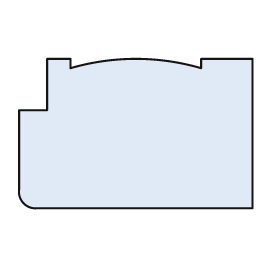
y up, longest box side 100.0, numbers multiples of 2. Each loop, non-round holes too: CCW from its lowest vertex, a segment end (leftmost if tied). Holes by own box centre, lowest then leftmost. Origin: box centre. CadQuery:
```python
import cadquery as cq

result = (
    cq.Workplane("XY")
    .moveTo(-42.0, -32.0)
    .lineTo(50.0, -32.0)
    .lineTo(50.0, 32.0)
    .lineTo(28.0, 32.0)
    .lineTo(28.0, 28.0)
    .threePointArc((0.0, 32.0), (-28.0, 28.0))
    .lineTo(-28.0, 32.0)
    .lineTo(-38.0, 32.0)
    .lineTo(-38.0, 10.0)
    .lineTo(-50.0, 10.0)
    .lineTo(-50.0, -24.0)
    .threePointArc((-48.0, -30.0), (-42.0, -32.0))
    .close()
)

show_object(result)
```